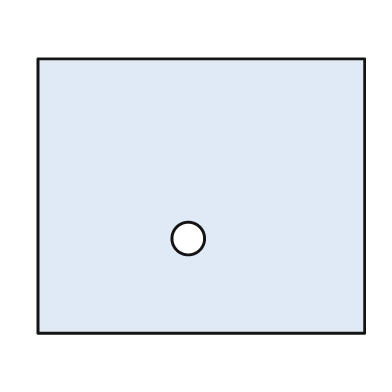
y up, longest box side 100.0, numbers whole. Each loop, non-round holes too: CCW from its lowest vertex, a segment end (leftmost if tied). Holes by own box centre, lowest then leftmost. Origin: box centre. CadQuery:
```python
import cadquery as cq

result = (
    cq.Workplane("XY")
    .moveTo(-50.0, -42.0)
    .lineTo(50.0, -42.0)
    .lineTo(50.0, 42.0)
    .lineTo(-50.0, 42.0)
    .close()
    .moveTo(-4.0, -13.0)
    .circle(5.0)
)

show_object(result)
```